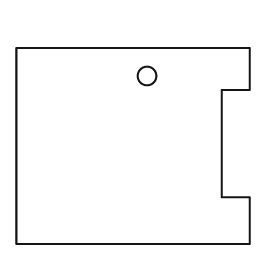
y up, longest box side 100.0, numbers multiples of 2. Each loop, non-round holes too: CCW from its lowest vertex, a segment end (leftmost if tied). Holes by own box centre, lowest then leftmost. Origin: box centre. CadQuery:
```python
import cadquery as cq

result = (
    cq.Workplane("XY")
    .moveTo(-50.0, -42.0)
    .lineTo(50.0, -42.0)
    .lineTo(50.0, -22.0)
    .lineTo(38.0, -22.0)
    .lineTo(38.0, 24.0)
    .lineTo(50.0, 24.0)
    .lineTo(50.0, 42.0)
    .lineTo(-50.0, 42.0)
    .close()
    .moveTo(6.0, 30.0)
    .circle(4.0)
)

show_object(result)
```